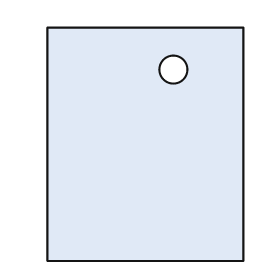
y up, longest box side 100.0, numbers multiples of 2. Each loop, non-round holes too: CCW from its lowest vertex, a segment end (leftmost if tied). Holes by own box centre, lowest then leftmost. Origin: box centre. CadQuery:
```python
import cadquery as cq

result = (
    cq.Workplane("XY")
    .moveTo(-42.0, -50.0)
    .lineTo(42.0, -50.0)
    .lineTo(42.0, 50.0)
    .lineTo(-42.0, 50.0)
    .close()
    .moveTo(12.0, 32.0)
    .circle(6.0)
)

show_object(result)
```